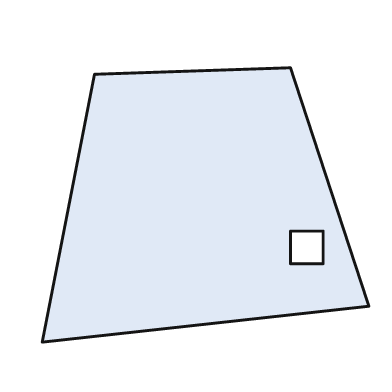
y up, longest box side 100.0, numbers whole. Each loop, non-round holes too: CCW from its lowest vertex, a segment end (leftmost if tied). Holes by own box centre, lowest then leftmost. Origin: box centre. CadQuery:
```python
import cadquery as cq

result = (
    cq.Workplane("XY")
    .moveTo(-50.0, -42.0)
    .lineTo(50.0, -31.0)
    .lineTo(26.0, 42.0)
    .lineTo(-34.0, 40.0)
    .close()
    .moveTo(26.0, -18.0)
    .lineTo(36.0, -18.0)
    .lineTo(36.0, -8.0)
    .lineTo(26.0, -8.0)
    .close()
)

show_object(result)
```